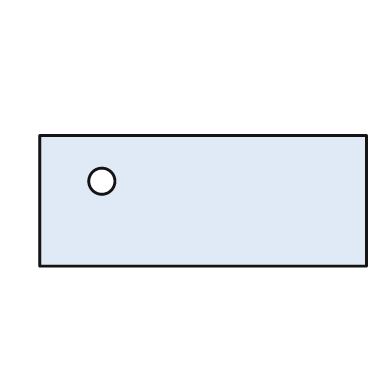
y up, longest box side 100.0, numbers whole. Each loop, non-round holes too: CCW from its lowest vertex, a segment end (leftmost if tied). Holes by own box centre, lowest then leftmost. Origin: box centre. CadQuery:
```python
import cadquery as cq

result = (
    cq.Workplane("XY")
    .moveTo(-50.0, -20.0)
    .lineTo(50.0, -20.0)
    .lineTo(50.0, 20.0)
    .lineTo(-50.0, 20.0)
    .close()
    .moveTo(-31.0, 6.0)
    .circle(4.0)
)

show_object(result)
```